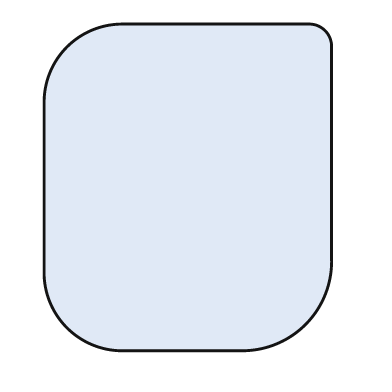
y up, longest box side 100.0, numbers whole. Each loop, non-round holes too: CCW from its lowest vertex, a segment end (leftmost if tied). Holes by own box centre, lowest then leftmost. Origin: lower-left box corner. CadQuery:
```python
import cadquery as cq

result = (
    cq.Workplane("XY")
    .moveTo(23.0, 0.0)
    .lineTo(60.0, 0.0)
    .threePointArc((80.0, 8.0), (88.0, 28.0))
    .lineTo(88.0, 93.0)
    .threePointArc((86.0, 98.0), (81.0, 100.0))
    .lineTo(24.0, 100.0)
    .threePointArc((7.0, 93.0), (0.0, 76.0))
    .lineTo(0.0, 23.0)
    .threePointArc((7.0, 7.0), (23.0, 0.0))
    .close()
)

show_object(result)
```